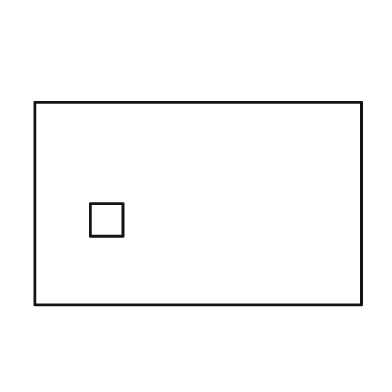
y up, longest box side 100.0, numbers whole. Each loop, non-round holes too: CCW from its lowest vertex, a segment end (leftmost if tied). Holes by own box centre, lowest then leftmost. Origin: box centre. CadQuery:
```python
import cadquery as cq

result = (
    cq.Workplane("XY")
    .moveTo(-50.0, -31.0)
    .lineTo(50.0, -31.0)
    .lineTo(50.0, 31.0)
    .lineTo(-50.0, 31.0)
    .close()
    .moveTo(-33.0, -10.0)
    .lineTo(-23.0, -10.0)
    .lineTo(-23.0, 0.0)
    .lineTo(-33.0, 0.0)
    .close()
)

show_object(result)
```